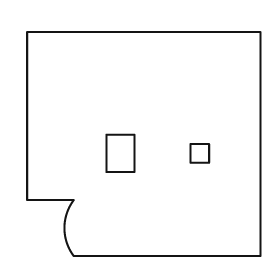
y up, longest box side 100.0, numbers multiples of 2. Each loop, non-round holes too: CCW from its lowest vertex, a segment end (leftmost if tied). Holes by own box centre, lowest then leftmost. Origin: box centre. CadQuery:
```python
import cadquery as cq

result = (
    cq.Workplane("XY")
    .moveTo(-30.0, -48.0)
    .lineTo(50.0, -48.0)
    .lineTo(50.0, 48.0)
    .lineTo(-50.0, 48.0)
    .lineTo(-50.0, -24.0)
    .lineTo(-30.0, -24.0)
    .threePointArc((-34.0, -36.0), (-30.0, -48.0))
    .close()
    .moveTo(-16.0, -12.0)
    .lineTo(-4.0, -12.0)
    .lineTo(-4.0, 4.0)
    .lineTo(-16.0, 4.0)
    .close()
    .moveTo(20.0, -8.0)
    .lineTo(28.0, -8.0)
    .lineTo(28.0, 0.0)
    .lineTo(20.0, 0.0)
    .close()
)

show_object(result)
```